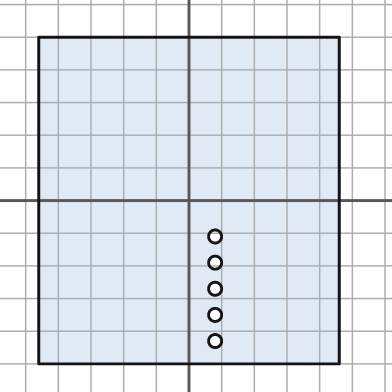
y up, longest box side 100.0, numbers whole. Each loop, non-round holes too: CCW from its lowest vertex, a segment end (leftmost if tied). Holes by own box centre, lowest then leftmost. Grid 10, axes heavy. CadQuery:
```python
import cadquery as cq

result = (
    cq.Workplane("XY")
    .moveTo(-46.0, -50.0)
    .lineTo(46.0, -50.0)
    .lineTo(46.0, 50.0)
    .lineTo(-46.0, 50.0)
    .close()
    .moveTo(8.0, -43.0)
    .circle(2.0)
    .moveTo(8.0, -35.0)
    .circle(2.0)
    .moveTo(8.0, -27.0)
    .circle(2.0)
    .moveTo(8.0, -19.0)
    .circle(2.0)
    .moveTo(8.0, -11.0)
    .circle(2.0)
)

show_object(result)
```